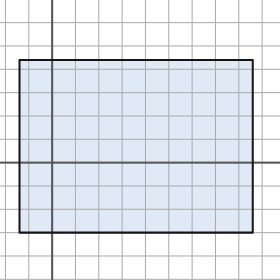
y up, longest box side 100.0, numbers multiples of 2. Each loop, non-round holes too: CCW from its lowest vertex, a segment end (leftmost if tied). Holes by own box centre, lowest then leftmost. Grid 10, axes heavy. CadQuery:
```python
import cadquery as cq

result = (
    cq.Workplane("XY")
    .moveTo(-14.0, -30.0)
    .lineTo(86.0, -30.0)
    .lineTo(86.0, 44.0)
    .lineTo(-14.0, 44.0)
    .close()
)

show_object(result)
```